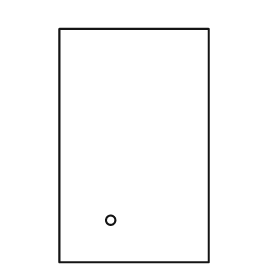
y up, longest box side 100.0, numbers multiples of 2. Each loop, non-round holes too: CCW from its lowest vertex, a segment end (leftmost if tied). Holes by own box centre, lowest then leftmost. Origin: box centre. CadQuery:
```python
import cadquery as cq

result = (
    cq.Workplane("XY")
    .moveTo(-32.0, -50.0)
    .lineTo(32.0, -50.0)
    .lineTo(32.0, 50.0)
    .lineTo(-32.0, 50.0)
    .close()
    .moveTo(-10.0, -32.0)
    .circle(2.0)
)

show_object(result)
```